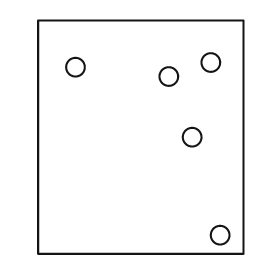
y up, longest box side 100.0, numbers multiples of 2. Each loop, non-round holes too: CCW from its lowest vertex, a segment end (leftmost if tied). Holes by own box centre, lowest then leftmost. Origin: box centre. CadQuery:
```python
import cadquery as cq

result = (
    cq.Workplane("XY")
    .moveTo(-44.0, -50.0)
    .lineTo(44.0, -50.0)
    .lineTo(44.0, 50.0)
    .lineTo(-44.0, 50.0)
    .close()
    .moveTo(34.0, -42.0)
    .circle(4.0)
    .moveTo(22.0, 0.0)
    .circle(4.0)
    .moveTo(12.0, 26.0)
    .circle(4.0)
    .moveTo(-28.0, 30.0)
    .circle(4.0)
    .moveTo(30.0, 32.0)
    .circle(4.0)
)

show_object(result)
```